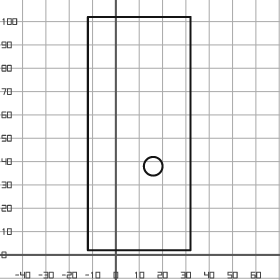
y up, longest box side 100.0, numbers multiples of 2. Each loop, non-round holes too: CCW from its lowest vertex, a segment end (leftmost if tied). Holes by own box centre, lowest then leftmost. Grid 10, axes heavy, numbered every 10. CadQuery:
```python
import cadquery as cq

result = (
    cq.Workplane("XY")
    .moveTo(-12.0, 2.0)
    .lineTo(32.0, 2.0)
    .lineTo(32.0, 102.0)
    .lineTo(-12.0, 102.0)
    .close()
    .moveTo(16.0, 38.0)
    .circle(4.0)
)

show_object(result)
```